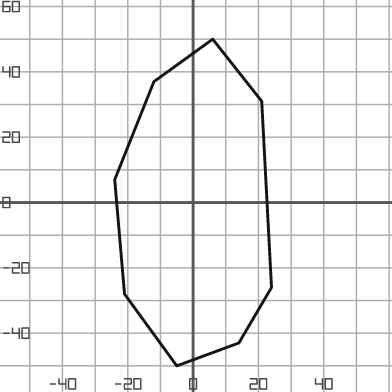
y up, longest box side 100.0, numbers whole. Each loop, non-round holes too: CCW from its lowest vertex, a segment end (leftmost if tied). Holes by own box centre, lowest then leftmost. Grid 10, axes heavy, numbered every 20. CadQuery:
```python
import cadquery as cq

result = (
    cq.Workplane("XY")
    .moveTo(-5.0, -50.0)
    .lineTo(14.0, -43.0)
    .lineTo(24.0, -26.0)
    .lineTo(21.0, 31.0)
    .lineTo(6.0, 50.0)
    .lineTo(-12.0, 37.0)
    .lineTo(-24.0, 7.0)
    .lineTo(-21.0, -28.0)
    .close()
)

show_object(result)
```